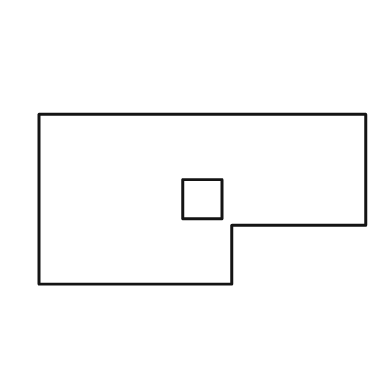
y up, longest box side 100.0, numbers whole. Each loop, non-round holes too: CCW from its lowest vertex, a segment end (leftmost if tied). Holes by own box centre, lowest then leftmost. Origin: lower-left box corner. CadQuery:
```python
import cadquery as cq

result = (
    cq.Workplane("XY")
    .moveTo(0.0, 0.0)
    .lineTo(59.0, 0.0)
    .lineTo(59.0, 18.0)
    .lineTo(100.0, 18.0)
    .lineTo(100.0, 52.0)
    .lineTo(0.0, 52.0)
    .close()
    .moveTo(44.0, 20.0)
    .lineTo(56.0, 20.0)
    .lineTo(56.0, 32.0)
    .lineTo(44.0, 32.0)
    .close()
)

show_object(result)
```